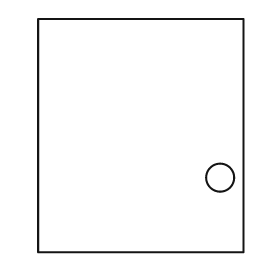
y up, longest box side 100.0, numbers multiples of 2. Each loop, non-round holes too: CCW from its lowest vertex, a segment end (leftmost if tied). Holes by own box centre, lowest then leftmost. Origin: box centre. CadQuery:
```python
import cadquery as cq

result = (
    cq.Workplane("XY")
    .moveTo(-44.0, -50.0)
    .lineTo(44.0, -50.0)
    .lineTo(44.0, 50.0)
    .lineTo(-44.0, 50.0)
    .close()
    .moveTo(34.0, -18.0)
    .circle(6.0)
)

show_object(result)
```